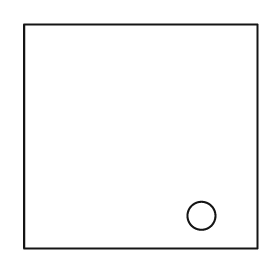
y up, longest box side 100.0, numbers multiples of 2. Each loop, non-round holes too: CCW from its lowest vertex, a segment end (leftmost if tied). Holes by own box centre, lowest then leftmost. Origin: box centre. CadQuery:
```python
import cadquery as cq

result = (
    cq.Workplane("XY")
    .moveTo(-50.0, -48.0)
    .lineTo(50.0, -48.0)
    .lineTo(50.0, 48.0)
    .lineTo(-50.0, 48.0)
    .close()
    .moveTo(26.0, -34.0)
    .circle(6.0)
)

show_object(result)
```